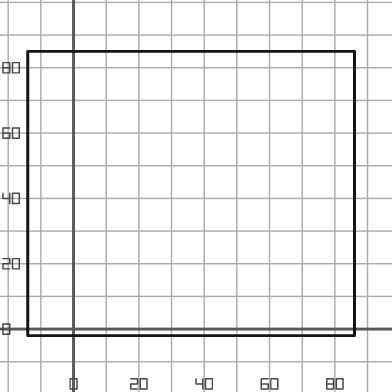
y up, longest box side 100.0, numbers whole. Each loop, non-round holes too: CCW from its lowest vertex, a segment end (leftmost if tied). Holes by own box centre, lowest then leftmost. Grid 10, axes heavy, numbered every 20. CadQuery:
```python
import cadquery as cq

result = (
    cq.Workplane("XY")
    .moveTo(-14.0, -2.0)
    .lineTo(86.0, -2.0)
    .lineTo(86.0, 85.0)
    .lineTo(-14.0, 85.0)
    .close()
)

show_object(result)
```